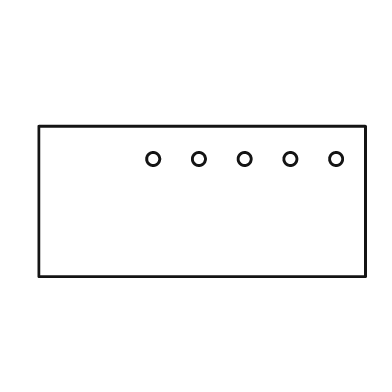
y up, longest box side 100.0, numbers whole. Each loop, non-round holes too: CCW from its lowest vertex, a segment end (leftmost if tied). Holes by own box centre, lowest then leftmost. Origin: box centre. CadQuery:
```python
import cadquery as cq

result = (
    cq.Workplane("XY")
    .moveTo(-50.0, -23.0)
    .lineTo(50.0, -23.0)
    .lineTo(50.0, 23.0)
    .lineTo(-50.0, 23.0)
    .close()
    .moveTo(-15.0, 13.0)
    .circle(2.0)
    .moveTo(-1.0, 13.0)
    .circle(2.0)
    .moveTo(13.0, 13.0)
    .circle(2.0)
    .moveTo(27.0, 13.0)
    .circle(2.0)
    .moveTo(41.0, 13.0)
    .circle(2.0)
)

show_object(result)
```